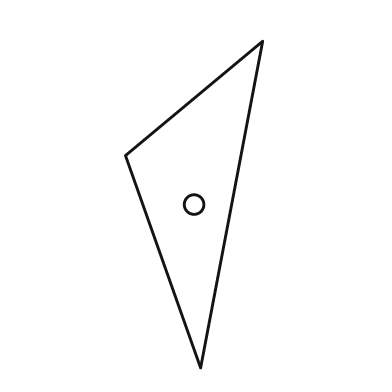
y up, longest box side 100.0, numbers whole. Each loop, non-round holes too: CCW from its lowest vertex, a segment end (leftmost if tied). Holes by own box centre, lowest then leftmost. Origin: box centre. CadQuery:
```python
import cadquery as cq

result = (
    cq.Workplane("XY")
    .moveTo(2.0, -50.0)
    .lineTo(21.0, 50.0)
    .lineTo(-21.0, 15.0)
    .close()
    .moveTo(0.0, 0.0)
    .circle(3.0)
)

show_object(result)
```